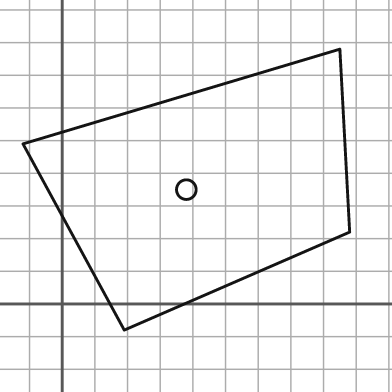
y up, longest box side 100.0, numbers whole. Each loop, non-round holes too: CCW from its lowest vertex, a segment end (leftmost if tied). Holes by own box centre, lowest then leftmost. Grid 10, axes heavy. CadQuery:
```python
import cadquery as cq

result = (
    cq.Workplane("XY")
    .moveTo(19.0, -8.0)
    .lineTo(88.0, 22.0)
    .lineTo(85.0, 78.0)
    .lineTo(-12.0, 49.0)
    .close()
    .moveTo(38.0, 35.0)
    .circle(3.0)
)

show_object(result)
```